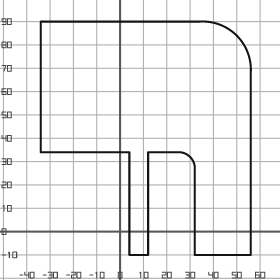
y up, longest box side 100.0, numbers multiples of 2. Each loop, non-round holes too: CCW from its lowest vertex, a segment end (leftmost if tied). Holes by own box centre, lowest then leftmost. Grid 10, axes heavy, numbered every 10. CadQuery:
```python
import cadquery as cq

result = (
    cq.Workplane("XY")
    .moveTo(4.0, -10.0)
    .lineTo(12.0, -10.0)
    .lineTo(12.0, 34.0)
    .lineTo(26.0, 34.0)
    .threePointArc((30.0, 32.0), (32.0, 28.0))
    .lineTo(32.0, -10.0)
    .lineTo(56.0, -10.0)
    .lineTo(56.0, 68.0)
    .threePointArc((50.0, 84.0), (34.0, 90.0))
    .lineTo(-34.0, 90.0)
    .lineTo(-34.0, 34.0)
    .lineTo(4.0, 34.0)
    .close()
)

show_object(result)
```